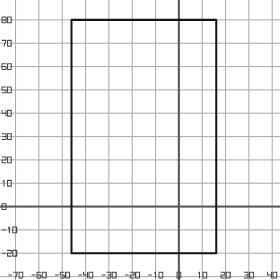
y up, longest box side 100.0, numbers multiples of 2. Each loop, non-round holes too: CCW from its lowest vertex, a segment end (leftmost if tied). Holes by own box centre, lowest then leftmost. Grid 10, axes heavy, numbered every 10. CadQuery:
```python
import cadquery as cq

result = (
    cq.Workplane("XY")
    .moveTo(-46.0, -20.0)
    .lineTo(16.0, -20.0)
    .lineTo(16.0, 80.0)
    .lineTo(-46.0, 80.0)
    .close()
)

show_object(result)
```